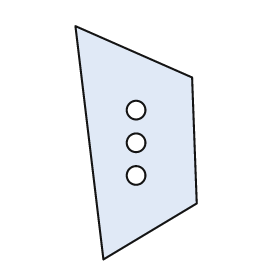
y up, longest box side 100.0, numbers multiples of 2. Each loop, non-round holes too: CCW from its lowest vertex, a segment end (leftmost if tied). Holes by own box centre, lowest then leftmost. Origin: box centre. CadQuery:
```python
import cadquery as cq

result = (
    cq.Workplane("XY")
    .moveTo(-14.0, -50.0)
    .lineTo(26.0, -26.0)
    .lineTo(24.0, 28.0)
    .lineTo(-26.0, 50.0)
    .close()
    .moveTo(0.0, -14.0)
    .circle(4.0)
    .moveTo(0.0, 0.0)
    .circle(4.0)
    .moveTo(0.0, 14.0)
    .circle(4.0)
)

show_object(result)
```